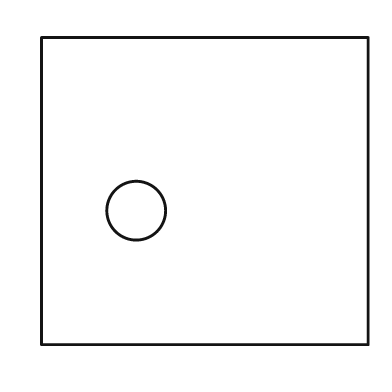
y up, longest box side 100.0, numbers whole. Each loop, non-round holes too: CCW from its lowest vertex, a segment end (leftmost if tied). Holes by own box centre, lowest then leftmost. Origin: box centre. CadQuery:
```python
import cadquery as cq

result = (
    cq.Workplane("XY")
    .moveTo(-50.0, -47.0)
    .lineTo(50.0, -47.0)
    .lineTo(50.0, 47.0)
    .lineTo(-50.0, 47.0)
    .close()
    .moveTo(-21.0, -6.0)
    .circle(9.0)
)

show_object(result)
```